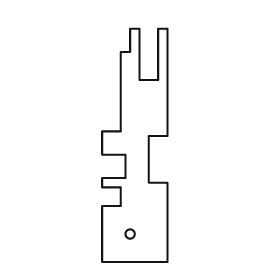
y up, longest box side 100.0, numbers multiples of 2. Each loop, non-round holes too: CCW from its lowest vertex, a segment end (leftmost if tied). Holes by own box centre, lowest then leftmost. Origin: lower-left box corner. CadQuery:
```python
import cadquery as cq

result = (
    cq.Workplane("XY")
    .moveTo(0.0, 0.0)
    .lineTo(28.0, 0.0)
    .lineTo(28.0, 34.0)
    .lineTo(20.0, 34.0)
    .lineTo(20.0, 54.0)
    .lineTo(28.0, 54.0)
    .lineTo(28.0, 100.0)
    .lineTo(24.0, 100.0)
    .lineTo(24.0, 78.0)
    .lineTo(16.0, 78.0)
    .lineTo(16.0, 100.0)
    .lineTo(12.0, 100.0)
    .lineTo(12.0, 90.0)
    .lineTo(8.0, 90.0)
    .lineTo(8.0, 56.0)
    .lineTo(0.0, 56.0)
    .lineTo(0.0, 46.0)
    .lineTo(10.0, 46.0)
    .lineTo(10.0, 36.0)
    .lineTo(0.0, 36.0)
    .lineTo(0.0, 32.0)
    .lineTo(8.0, 32.0)
    .lineTo(8.0, 24.0)
    .lineTo(0.0, 24.0)
    .close()
    .moveTo(12.0, 12.0)
    .circle(2.0)
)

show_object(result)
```